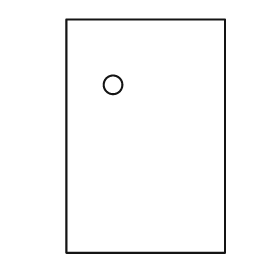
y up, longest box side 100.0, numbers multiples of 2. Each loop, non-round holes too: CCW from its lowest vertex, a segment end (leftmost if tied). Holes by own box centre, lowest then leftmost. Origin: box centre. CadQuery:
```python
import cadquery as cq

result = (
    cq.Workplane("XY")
    .moveTo(-34.0, -50.0)
    .lineTo(34.0, -50.0)
    .lineTo(34.0, 50.0)
    .lineTo(-34.0, 50.0)
    .close()
    .moveTo(-14.0, 22.0)
    .circle(4.0)
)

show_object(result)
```